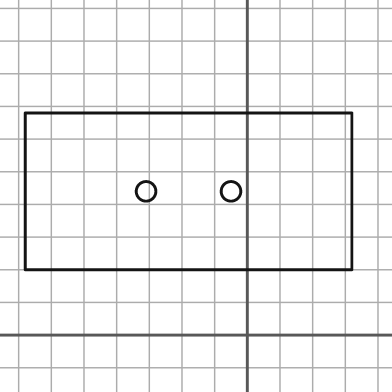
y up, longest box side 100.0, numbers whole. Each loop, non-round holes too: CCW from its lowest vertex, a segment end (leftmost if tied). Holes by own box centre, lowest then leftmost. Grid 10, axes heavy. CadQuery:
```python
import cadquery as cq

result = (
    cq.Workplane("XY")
    .moveTo(-68.0, 20.0)
    .lineTo(32.0, 20.0)
    .lineTo(32.0, 68.0)
    .lineTo(-68.0, 68.0)
    .close()
    .moveTo(-31.0, 44.0)
    .circle(3.0)
    .moveTo(-5.0, 44.0)
    .circle(3.0)
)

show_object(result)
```